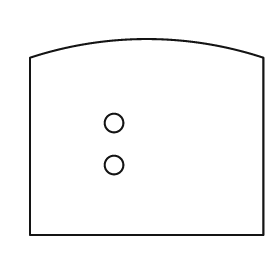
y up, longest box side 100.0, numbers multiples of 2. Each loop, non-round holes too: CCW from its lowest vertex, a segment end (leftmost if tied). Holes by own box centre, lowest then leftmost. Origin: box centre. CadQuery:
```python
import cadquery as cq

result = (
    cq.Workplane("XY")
    .moveTo(-50.0, -42.0)
    .lineTo(50.0, -42.0)
    .lineTo(50.0, 34.0)
    .threePointArc((0.0, 42.0), (-50.0, 34.0))
    .close()
    .moveTo(-14.0, -12.0)
    .circle(4.0)
    .moveTo(-14.0, 6.0)
    .circle(4.0)
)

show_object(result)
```